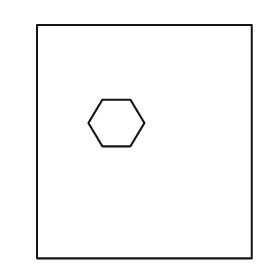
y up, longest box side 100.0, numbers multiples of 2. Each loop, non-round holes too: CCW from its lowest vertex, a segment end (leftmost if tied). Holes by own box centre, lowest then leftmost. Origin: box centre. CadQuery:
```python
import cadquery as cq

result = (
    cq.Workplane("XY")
    .moveTo(-46.0, -50.0)
    .lineTo(46.0, -50.0)
    .lineTo(46.0, 50.0)
    .lineTo(-46.0, 50.0)
    .close()
    .moveTo(-18.0, -2.0)
    .lineTo(-6.0, -2.0)
    .lineTo(0.0, 8.0)
    .lineTo(-6.0, 18.0)
    .lineTo(-18.0, 18.0)
    .lineTo(-24.0, 8.0)
    .close()
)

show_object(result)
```